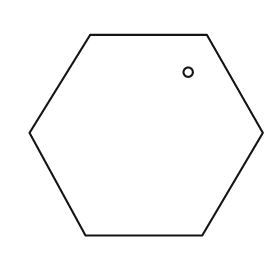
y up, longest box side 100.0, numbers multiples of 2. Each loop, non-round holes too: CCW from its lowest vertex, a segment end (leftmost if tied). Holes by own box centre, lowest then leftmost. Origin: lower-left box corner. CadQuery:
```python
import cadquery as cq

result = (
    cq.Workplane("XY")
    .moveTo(24.0, 0.0)
    .lineTo(74.0, 0.0)
    .lineTo(100.0, 44.0)
    .lineTo(76.0, 86.0)
    .lineTo(26.0, 86.0)
    .lineTo(0.0, 44.0)
    .close()
    .moveTo(68.0, 70.0)
    .circle(2.0)
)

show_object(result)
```